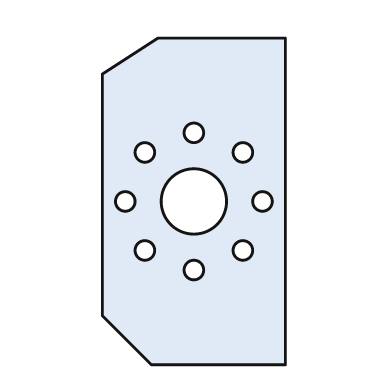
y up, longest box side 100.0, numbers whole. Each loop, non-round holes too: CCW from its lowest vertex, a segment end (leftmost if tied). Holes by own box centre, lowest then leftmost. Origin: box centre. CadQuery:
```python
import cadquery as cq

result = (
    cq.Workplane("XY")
    .moveTo(-13.0, -50.0)
    .lineTo(28.0, -50.0)
    .lineTo(28.0, 50.0)
    .lineTo(-11.0, 50.0)
    .lineTo(-28.0, 39.0)
    .lineTo(-28.0, -35.0)
    .close()
    .moveTo(0.0, -21.0)
    .circle(3.0)
    .moveTo(-15.0, -15.0)
    .circle(3.0)
    .moveTo(15.0, -15.0)
    .circle(3.0)
    .moveTo(-21.0, 0.0)
    .circle(3.0)
    .moveTo(0.0, 0.0)
    .circle(10.0)
    .moveTo(21.0, 0.0)
    .circle(3.0)
    .moveTo(-15.0, 15.0)
    .circle(3.0)
    .moveTo(15.0, 15.0)
    .circle(3.0)
    .moveTo(0.0, 21.0)
    .circle(3.0)
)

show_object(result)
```